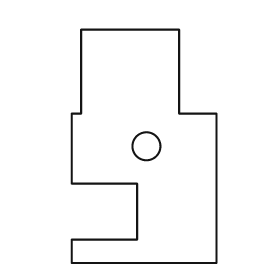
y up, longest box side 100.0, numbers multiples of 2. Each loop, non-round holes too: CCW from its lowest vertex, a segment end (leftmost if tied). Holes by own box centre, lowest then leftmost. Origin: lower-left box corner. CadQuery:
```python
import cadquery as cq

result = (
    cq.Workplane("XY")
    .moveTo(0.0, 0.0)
    .lineTo(62.0, 0.0)
    .lineTo(62.0, 64.0)
    .lineTo(46.0, 64.0)
    .lineTo(46.0, 100.0)
    .lineTo(4.0, 100.0)
    .lineTo(4.0, 64.0)
    .lineTo(0.0, 64.0)
    .lineTo(0.0, 34.0)
    .lineTo(28.0, 34.0)
    .lineTo(28.0, 10.0)
    .lineTo(0.0, 10.0)
    .close()
    .moveTo(32.0, 50.0)
    .circle(6.0)
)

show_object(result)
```